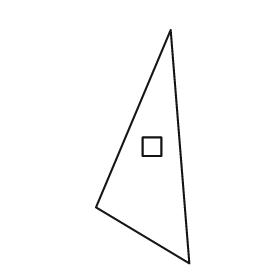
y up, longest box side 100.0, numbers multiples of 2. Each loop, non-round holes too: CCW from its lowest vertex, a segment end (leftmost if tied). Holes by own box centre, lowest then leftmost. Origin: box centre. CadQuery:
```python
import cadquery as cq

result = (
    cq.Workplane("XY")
    .moveTo(20.0, -50.0)
    .lineTo(12.0, 50.0)
    .lineTo(-20.0, -26.0)
    .close()
    .moveTo(0.0, -4.0)
    .lineTo(8.0, -4.0)
    .lineTo(8.0, 4.0)
    .lineTo(0.0, 4.0)
    .close()
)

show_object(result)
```